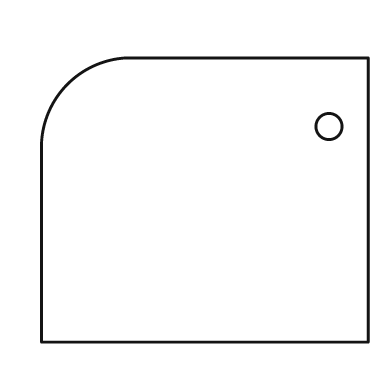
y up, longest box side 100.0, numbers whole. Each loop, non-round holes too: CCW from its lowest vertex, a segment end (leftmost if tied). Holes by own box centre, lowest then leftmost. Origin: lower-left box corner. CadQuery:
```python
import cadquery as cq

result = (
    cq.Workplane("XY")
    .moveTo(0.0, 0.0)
    .lineTo(100.0, 0.0)
    .lineTo(100.0, 87.0)
    .lineTo(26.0, 87.0)
    .threePointArc((8.0, 79.0), (0.0, 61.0))
    .close()
    .moveTo(88.0, 66.0)
    .circle(4.0)
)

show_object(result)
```